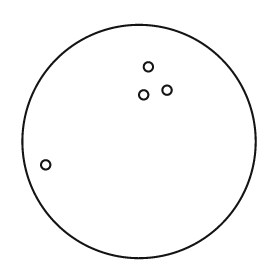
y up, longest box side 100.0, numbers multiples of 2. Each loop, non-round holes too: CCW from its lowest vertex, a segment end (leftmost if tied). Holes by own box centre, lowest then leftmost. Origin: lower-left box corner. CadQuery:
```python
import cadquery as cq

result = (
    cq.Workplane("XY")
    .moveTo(50.0, 50.0)
    .circle(50.0)
    .moveTo(10.0, 40.0)
    .circle(2.0)
    .moveTo(52.0, 70.0)
    .circle(2.0)
    .moveTo(62.0, 72.0)
    .circle(2.0)
    .moveTo(54.0, 82.0)
    .circle(2.0)
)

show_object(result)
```